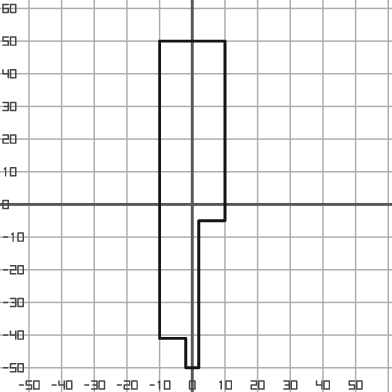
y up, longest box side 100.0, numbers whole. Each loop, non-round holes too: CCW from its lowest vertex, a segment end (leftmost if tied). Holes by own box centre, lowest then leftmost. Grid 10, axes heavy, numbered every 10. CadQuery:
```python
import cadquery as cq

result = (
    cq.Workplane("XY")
    .moveTo(-2.0, -50.0)
    .lineTo(2.0, -50.0)
    .lineTo(2.0, -5.0)
    .lineTo(10.0, -5.0)
    .lineTo(10.0, 50.0)
    .lineTo(-10.0, 50.0)
    .lineTo(-10.0, -41.0)
    .lineTo(-2.0, -41.0)
    .close()
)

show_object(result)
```